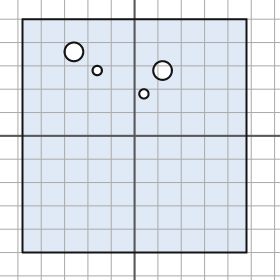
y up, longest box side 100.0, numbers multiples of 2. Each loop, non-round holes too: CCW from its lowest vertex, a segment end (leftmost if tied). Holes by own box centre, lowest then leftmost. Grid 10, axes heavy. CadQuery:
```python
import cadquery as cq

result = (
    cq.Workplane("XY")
    .moveTo(-48.0, -50.0)
    .lineTo(48.0, -50.0)
    .lineTo(48.0, 50.0)
    .lineTo(-48.0, 50.0)
    .close()
    .moveTo(4.0, 18.0)
    .circle(2.0)
    .moveTo(-16.0, 28.0)
    .circle(2.0)
    .moveTo(12.0, 28.0)
    .circle(4.0)
    .moveTo(-26.0, 36.0)
    .circle(4.0)
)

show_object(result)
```